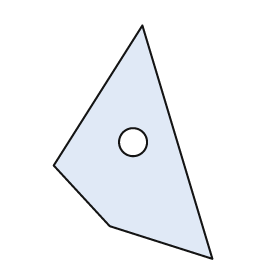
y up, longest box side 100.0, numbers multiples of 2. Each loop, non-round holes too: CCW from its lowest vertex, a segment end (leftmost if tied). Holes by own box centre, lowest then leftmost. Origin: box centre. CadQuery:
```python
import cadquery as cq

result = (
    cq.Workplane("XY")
    .moveTo(34.0, -50.0)
    .lineTo(4.0, 50.0)
    .lineTo(-34.0, -10.0)
    .lineTo(-10.0, -36.0)
    .close()
    .moveTo(0.0, 0.0)
    .circle(6.0)
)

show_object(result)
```